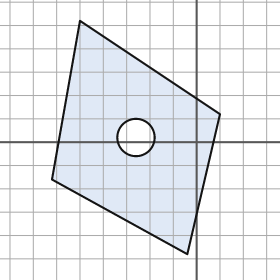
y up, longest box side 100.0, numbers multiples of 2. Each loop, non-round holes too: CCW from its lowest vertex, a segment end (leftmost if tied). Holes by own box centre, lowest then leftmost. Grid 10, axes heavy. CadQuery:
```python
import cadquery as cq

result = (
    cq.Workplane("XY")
    .moveTo(-4.0, -48.0)
    .lineTo(10.0, 12.0)
    .lineTo(-50.0, 52.0)
    .lineTo(-62.0, -16.0)
    .close()
    .moveTo(-26.0, 2.0)
    .circle(8.0)
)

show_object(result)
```